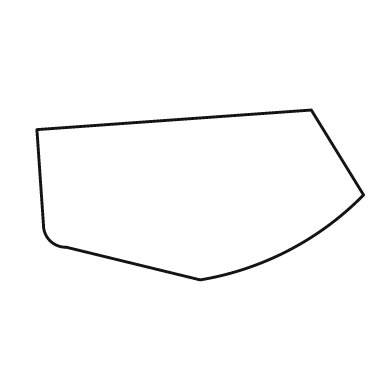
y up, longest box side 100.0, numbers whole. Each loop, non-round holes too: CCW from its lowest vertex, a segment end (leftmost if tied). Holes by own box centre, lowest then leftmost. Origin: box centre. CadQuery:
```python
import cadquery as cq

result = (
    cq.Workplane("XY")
    .moveTo(0.0, -26.0)
    .threePointArc((27.0, -17.0), (50.0, 0.0))
    .lineTo(34.0, 26.0)
    .lineTo(-50.0, 20.0)
    .lineTo(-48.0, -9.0)
    .threePointArc((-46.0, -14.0), (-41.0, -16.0))
    .close()
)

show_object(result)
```